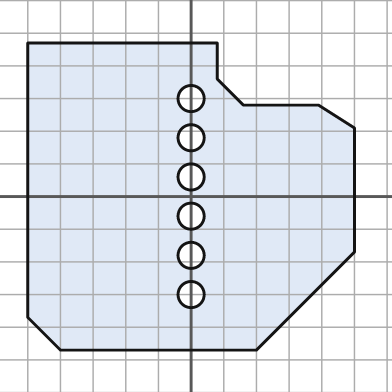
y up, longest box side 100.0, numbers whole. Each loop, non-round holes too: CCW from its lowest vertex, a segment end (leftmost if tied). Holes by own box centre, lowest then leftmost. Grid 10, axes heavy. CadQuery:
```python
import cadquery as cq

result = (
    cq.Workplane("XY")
    .moveTo(-40.0, -47.0)
    .lineTo(20.0, -47.0)
    .lineTo(50.0, -17.0)
    .lineTo(50.0, 21.0)
    .lineTo(39.0, 28.0)
    .lineTo(16.0, 28.0)
    .lineTo(8.0, 36.0)
    .lineTo(8.0, 47.0)
    .lineTo(-50.0, 47.0)
    .lineTo(-50.0, -37.0)
    .close()
    .moveTo(0.0, -30.0)
    .circle(4.0)
    .moveTo(0.0, -18.0)
    .circle(4.0)
    .moveTo(0.0, -6.0)
    .circle(4.0)
    .moveTo(0.0, 6.0)
    .circle(4.0)
    .moveTo(0.0, 18.0)
    .circle(4.0)
    .moveTo(0.0, 30.0)
    .circle(4.0)
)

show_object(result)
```